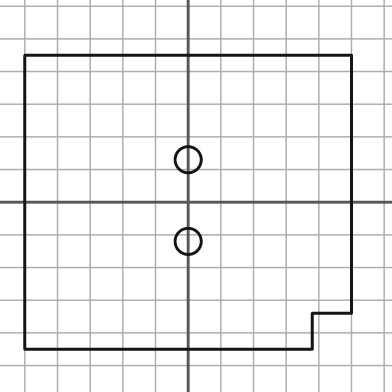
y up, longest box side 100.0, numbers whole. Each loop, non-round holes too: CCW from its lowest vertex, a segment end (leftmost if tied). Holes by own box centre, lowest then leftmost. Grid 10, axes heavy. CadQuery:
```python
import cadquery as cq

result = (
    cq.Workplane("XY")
    .moveTo(-50.0, -45.0)
    .lineTo(38.0, -45.0)
    .lineTo(38.0, -34.0)
    .lineTo(50.0, -34.0)
    .lineTo(50.0, 45.0)
    .lineTo(-50.0, 45.0)
    .close()
    .moveTo(0.0, -12.0)
    .circle(4.0)
    .moveTo(0.0, 13.0)
    .circle(4.0)
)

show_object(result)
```